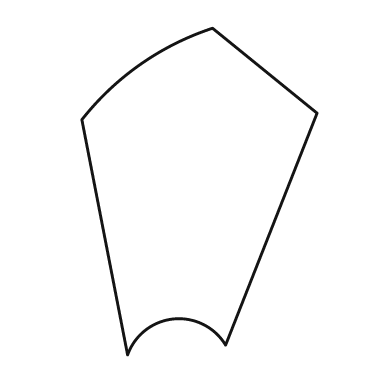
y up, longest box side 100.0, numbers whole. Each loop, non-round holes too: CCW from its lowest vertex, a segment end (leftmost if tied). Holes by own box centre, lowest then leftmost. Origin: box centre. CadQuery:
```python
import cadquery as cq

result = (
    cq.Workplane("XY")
    .moveTo(-22.0, -50.0)
    .threePointArc((-8.0, -39.0), (8.0, -47.0))
    .lineTo(36.0, 24.0)
    .lineTo(4.0, 50.0)
    .threePointArc((-18.0, 39.0), (-36.0, 22.0))
    .close()
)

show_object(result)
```